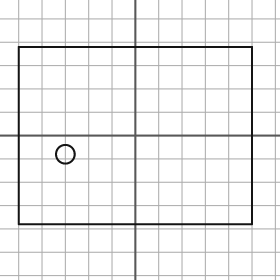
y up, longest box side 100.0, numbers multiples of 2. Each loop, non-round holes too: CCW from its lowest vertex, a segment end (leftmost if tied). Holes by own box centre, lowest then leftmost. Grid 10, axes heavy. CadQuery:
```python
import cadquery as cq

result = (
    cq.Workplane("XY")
    .moveTo(-50.0, -38.0)
    .lineTo(50.0, -38.0)
    .lineTo(50.0, 38.0)
    .lineTo(-50.0, 38.0)
    .close()
    .moveTo(-30.0, -8.0)
    .circle(4.0)
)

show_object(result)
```